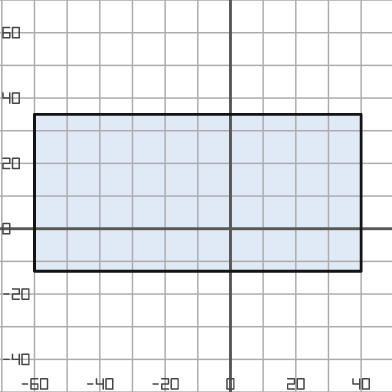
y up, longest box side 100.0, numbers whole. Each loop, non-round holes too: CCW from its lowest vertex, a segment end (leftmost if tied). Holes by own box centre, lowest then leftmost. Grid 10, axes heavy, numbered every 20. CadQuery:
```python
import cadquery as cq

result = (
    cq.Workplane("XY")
    .moveTo(-60.0, -13.0)
    .lineTo(40.0, -13.0)
    .lineTo(40.0, 35.0)
    .lineTo(-60.0, 35.0)
    .close()
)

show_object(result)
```